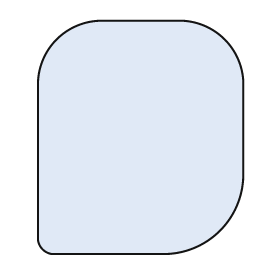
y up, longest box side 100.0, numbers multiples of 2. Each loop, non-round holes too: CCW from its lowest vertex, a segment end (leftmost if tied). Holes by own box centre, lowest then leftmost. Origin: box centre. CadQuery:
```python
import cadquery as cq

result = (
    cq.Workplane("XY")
    .moveTo(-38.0, -50.0)
    .lineTo(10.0, -50.0)
    .threePointArc((34.0, -40.0), (44.0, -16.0))
    .lineTo(44.0, 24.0)
    .threePointArc((36.0, 42.0), (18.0, 50.0))
    .lineTo(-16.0, 50.0)
    .threePointArc((-36.0, 42.0), (-44.0, 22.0))
    .lineTo(-44.0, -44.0)
    .threePointArc((-42.0, -48.0), (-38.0, -50.0))
    .close()
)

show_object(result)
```